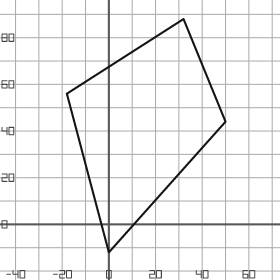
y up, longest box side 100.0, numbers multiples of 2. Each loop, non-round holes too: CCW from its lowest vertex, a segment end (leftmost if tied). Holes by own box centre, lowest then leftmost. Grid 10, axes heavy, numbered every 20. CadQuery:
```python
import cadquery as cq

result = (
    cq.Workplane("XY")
    .moveTo(0.0, -12.0)
    .lineTo(50.0, 44.0)
    .lineTo(32.0, 88.0)
    .lineTo(-18.0, 56.0)
    .close()
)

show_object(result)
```